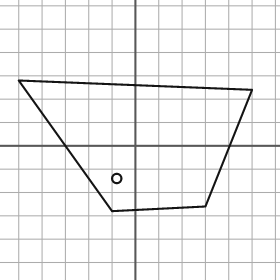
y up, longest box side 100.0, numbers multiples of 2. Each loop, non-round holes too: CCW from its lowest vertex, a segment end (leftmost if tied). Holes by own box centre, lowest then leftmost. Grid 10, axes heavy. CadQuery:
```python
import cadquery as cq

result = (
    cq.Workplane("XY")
    .moveTo(-10.0, -28.0)
    .lineTo(30.0, -26.0)
    .lineTo(50.0, 24.0)
    .lineTo(-50.0, 28.0)
    .close()
    .moveTo(-8.0, -14.0)
    .circle(2.0)
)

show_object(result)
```